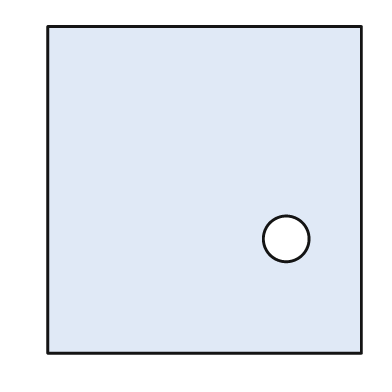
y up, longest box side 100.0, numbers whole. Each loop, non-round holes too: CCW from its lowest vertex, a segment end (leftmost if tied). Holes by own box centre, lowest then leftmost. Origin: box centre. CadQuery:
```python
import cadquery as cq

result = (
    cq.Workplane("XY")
    .moveTo(-48.0, -50.0)
    .lineTo(48.0, -50.0)
    .lineTo(48.0, 50.0)
    .lineTo(-48.0, 50.0)
    .close()
    .moveTo(25.0, -15.0)
    .circle(7.0)
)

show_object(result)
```